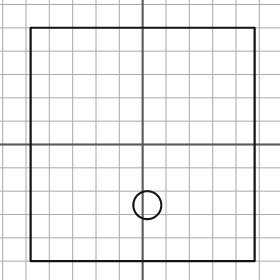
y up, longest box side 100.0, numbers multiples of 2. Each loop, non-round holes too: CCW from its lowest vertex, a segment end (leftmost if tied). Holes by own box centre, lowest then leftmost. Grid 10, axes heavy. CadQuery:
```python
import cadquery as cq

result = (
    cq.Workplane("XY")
    .moveTo(-48.0, -50.0)
    .lineTo(48.0, -50.0)
    .lineTo(48.0, 50.0)
    .lineTo(-48.0, 50.0)
    .close()
    .moveTo(2.0, -26.0)
    .circle(6.0)
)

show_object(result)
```